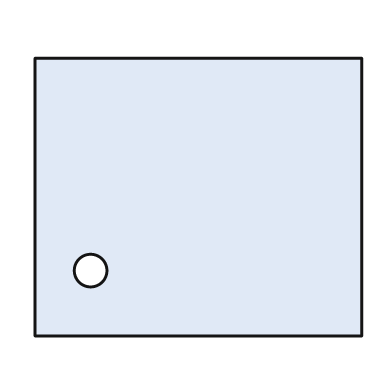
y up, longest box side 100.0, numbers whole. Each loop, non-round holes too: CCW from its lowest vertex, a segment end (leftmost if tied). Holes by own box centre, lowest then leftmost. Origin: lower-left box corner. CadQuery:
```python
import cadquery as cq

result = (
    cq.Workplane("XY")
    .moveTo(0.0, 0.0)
    .lineTo(100.0, 0.0)
    .lineTo(100.0, 85.0)
    .lineTo(0.0, 85.0)
    .close()
    .moveTo(17.0, 20.0)
    .circle(5.0)
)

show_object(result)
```